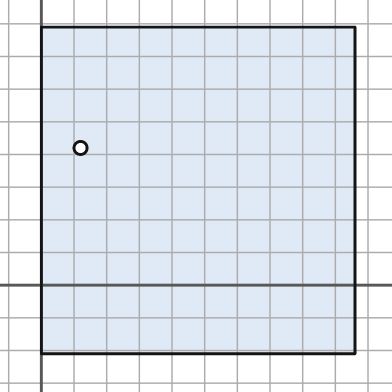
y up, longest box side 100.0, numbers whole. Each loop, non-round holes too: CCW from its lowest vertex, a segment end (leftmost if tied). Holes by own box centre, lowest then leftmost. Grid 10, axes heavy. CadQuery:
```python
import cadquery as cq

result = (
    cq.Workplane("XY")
    .moveTo(0.0, -21.0)
    .lineTo(96.0, -21.0)
    .lineTo(96.0, 79.0)
    .lineTo(0.0, 79.0)
    .close()
    .moveTo(12.0, 42.0)
    .circle(2.0)
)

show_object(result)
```